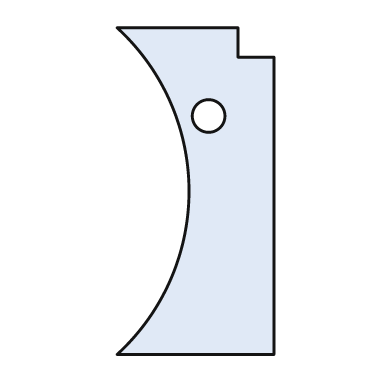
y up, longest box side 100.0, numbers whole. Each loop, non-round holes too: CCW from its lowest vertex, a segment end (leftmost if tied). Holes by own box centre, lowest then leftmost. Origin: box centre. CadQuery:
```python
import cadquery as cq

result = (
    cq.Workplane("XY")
    .moveTo(-24.0, -50.0)
    .lineTo(24.0, -50.0)
    .lineTo(24.0, 41.0)
    .lineTo(13.0, 41.0)
    .lineTo(13.0, 50.0)
    .lineTo(-24.0, 50.0)
    .threePointArc((-2.0, 0.0), (-24.0, -50.0))
    .close()
    .moveTo(4.0, 23.0)
    .circle(5.0)
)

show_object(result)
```